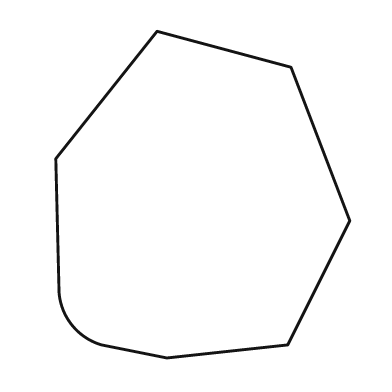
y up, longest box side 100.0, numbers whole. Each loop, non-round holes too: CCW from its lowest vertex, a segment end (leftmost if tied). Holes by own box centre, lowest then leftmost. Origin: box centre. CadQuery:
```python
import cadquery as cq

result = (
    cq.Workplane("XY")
    .moveTo(-11.0, -50.0)
    .lineTo(26.0, -46.0)
    .lineTo(45.0, -8.0)
    .lineTo(27.0, 39.0)
    .lineTo(-14.0, 50.0)
    .lineTo(-45.0, 11.0)
    .lineTo(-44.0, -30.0)
    .threePointArc((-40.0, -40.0), (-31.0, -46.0))
    .close()
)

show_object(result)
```